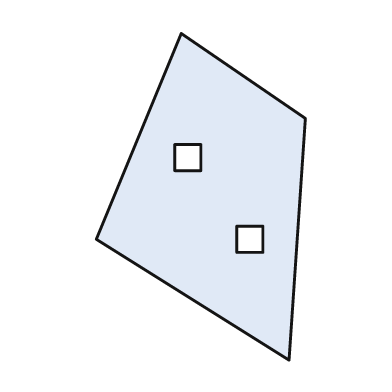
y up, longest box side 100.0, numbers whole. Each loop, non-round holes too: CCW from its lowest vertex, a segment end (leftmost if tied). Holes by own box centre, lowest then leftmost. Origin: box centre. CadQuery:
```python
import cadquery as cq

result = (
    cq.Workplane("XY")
    .moveTo(27.0, -50.0)
    .lineTo(32.0, 24.0)
    .lineTo(-6.0, 50.0)
    .lineTo(-32.0, -13.0)
    .close()
    .moveTo(11.0, -17.0)
    .lineTo(19.0, -17.0)
    .lineTo(19.0, -9.0)
    .lineTo(11.0, -9.0)
    .close()
    .moveTo(-8.0, 8.0)
    .lineTo(0.0, 8.0)
    .lineTo(0.0, 16.0)
    .lineTo(-8.0, 16.0)
    .close()
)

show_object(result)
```